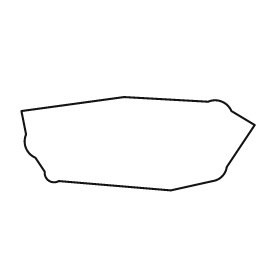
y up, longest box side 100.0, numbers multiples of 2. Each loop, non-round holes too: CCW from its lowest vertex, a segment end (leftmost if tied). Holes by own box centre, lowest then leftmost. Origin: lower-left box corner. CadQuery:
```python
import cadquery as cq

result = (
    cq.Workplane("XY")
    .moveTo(64.0, 0.0)
    .lineTo(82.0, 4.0)
    .threePointArc((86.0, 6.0), (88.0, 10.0))
    .lineTo(100.0, 28.0)
    .lineTo(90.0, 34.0)
    .threePointArc((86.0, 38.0), (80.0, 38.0))
    .lineTo(44.0, 40.0)
    .lineTo(0.0, 34.0)
    .lineTo(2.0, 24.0)
    .threePointArc((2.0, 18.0), (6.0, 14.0))
    .lineTo(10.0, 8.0)
    .threePointArc((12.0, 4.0), (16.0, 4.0))
    .close()
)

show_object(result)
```